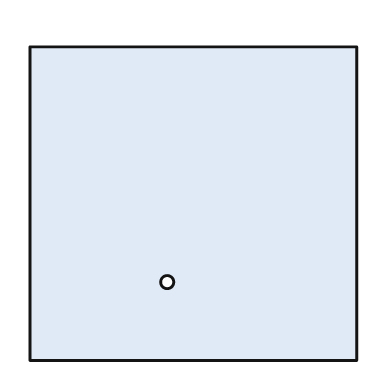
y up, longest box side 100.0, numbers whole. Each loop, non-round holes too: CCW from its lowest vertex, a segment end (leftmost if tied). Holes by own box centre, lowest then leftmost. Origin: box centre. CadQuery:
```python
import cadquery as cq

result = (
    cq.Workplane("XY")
    .moveTo(-50.0, -48.0)
    .lineTo(50.0, -48.0)
    .lineTo(50.0, 48.0)
    .lineTo(-50.0, 48.0)
    .close()
    .moveTo(-8.0, -24.0)
    .circle(2.0)
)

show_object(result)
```